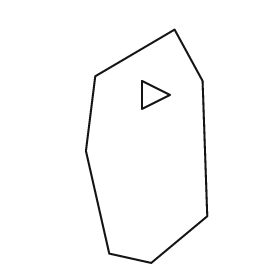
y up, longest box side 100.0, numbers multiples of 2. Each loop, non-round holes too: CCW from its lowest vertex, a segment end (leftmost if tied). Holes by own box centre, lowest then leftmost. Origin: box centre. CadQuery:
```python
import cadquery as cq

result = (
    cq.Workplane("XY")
    .moveTo(2.0, -50.0)
    .lineTo(26.0, -30.0)
    .lineTo(24.0, 28.0)
    .lineTo(12.0, 50.0)
    .lineTo(-22.0, 30.0)
    .lineTo(-26.0, -2.0)
    .lineTo(-16.0, -46.0)
    .close()
    .moveTo(-2.0, 16.0)
    .lineTo(10.0, 22.0)
    .lineTo(-2.0, 28.0)
    .close()
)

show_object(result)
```